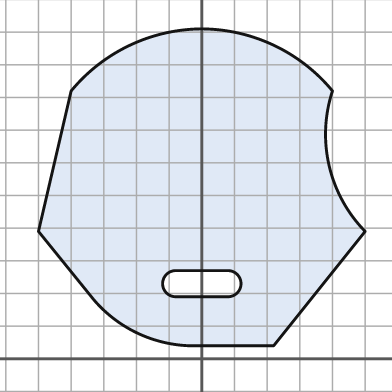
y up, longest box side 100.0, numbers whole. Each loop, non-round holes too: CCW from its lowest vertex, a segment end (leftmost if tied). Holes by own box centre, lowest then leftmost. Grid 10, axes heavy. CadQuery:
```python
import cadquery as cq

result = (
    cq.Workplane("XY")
    .moveTo(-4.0, 4.0)
    .lineTo(22.0, 4.0)
    .lineTo(50.0, 39.0)
    .threePointArc((39.0, 59.0), (40.0, 82.0))
    .threePointArc((22.0, 96.0), (0.0, 101.0))
    .threePointArc((-22.0, 96.0), (-40.0, 82.0))
    .lineTo(-50.0, 39.0)
    .lineTo(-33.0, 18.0)
    .threePointArc((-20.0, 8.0), (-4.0, 4.0))
    .close()
    .moveTo(-8.0, 19.0)
    .lineTo(8.0, 19.0)
    .threePointArc((12.0, 23.0), (8.0, 27.0))
    .lineTo(-8.0, 27.0)
    .threePointArc((-12.0, 23.0), (-8.0, 19.0))
    .close()
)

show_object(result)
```